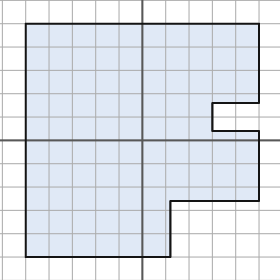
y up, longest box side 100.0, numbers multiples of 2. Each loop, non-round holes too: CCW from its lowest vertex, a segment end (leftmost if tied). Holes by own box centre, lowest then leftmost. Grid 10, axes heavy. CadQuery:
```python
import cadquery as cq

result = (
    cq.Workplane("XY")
    .moveTo(-50.0, -50.0)
    .lineTo(12.0, -50.0)
    .lineTo(12.0, -26.0)
    .lineTo(50.0, -26.0)
    .lineTo(50.0, 4.0)
    .lineTo(30.0, 4.0)
    .lineTo(30.0, 16.0)
    .lineTo(50.0, 16.0)
    .lineTo(50.0, 50.0)
    .lineTo(-50.0, 50.0)
    .close()
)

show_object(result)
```